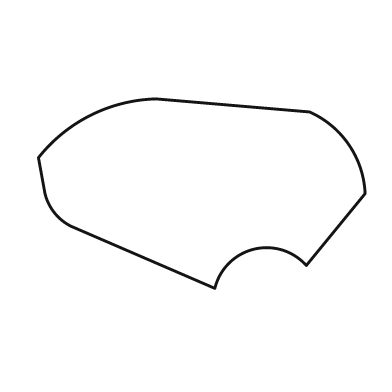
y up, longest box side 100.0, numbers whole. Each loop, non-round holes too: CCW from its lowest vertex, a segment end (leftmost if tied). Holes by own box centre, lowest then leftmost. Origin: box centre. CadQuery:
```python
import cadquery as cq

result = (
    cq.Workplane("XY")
    .moveTo(4.0, -29.0)
    .threePointArc((16.0, -17.0), (32.0, -22.0))
    .lineTo(50.0, 0.0)
    .threePointArc((45.0, 15.0), (33.0, 25.0))
    .lineTo(-14.0, 29.0)
    .threePointArc((-34.0, 24.0), (-50.0, 11.0))
    .lineTo(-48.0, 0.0)
    .threePointArc((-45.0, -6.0), (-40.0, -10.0))
    .close()
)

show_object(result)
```